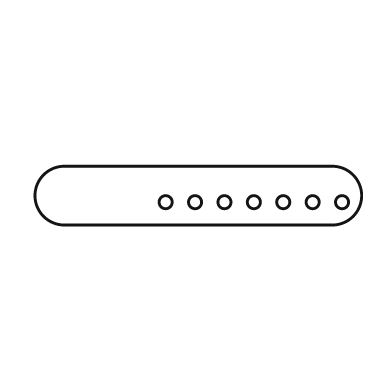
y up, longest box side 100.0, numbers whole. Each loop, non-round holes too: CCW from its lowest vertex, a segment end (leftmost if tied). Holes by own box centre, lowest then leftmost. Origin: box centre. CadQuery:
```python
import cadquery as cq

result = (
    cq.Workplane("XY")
    .moveTo(-41.0, -9.0)
    .lineTo(41.0, -9.0)
    .threePointArc((50.0, 0.0), (41.0, 9.0))
    .lineTo(-41.0, 9.0)
    .threePointArc((-50.0, 0.0), (-41.0, -9.0))
    .close()
    .moveTo(-10.0, -2.0)
    .circle(2.0)
    .moveTo(-1.0, -2.0)
    .circle(2.0)
    .moveTo(8.0, -2.0)
    .circle(2.0)
    .moveTo(17.0, -2.0)
    .circle(2.0)
    .moveTo(26.0, -2.0)
    .circle(2.0)
    .moveTo(35.0, -2.0)
    .circle(2.0)
    .moveTo(44.0, -2.0)
    .circle(2.0)
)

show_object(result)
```